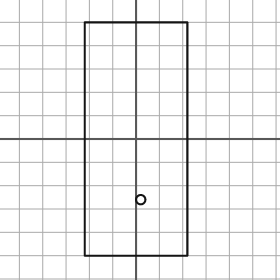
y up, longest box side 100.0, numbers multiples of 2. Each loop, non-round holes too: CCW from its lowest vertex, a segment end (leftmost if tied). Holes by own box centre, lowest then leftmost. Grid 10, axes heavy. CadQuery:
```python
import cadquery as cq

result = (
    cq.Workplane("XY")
    .moveTo(-22.0, -50.0)
    .lineTo(22.0, -50.0)
    .lineTo(22.0, 50.0)
    .lineTo(-22.0, 50.0)
    .close()
    .moveTo(2.0, -26.0)
    .circle(2.0)
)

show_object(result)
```